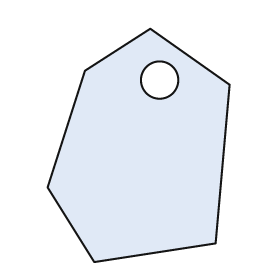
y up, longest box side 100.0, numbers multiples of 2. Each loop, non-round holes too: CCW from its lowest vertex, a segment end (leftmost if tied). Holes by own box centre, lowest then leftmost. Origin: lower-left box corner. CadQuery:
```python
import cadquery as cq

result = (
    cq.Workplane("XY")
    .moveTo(20.0, 0.0)
    .lineTo(72.0, 8.0)
    .lineTo(78.0, 76.0)
    .lineTo(44.0, 100.0)
    .lineTo(16.0, 82.0)
    .lineTo(0.0, 32.0)
    .close()
    .moveTo(48.0, 78.0)
    .circle(8.0)
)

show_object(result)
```